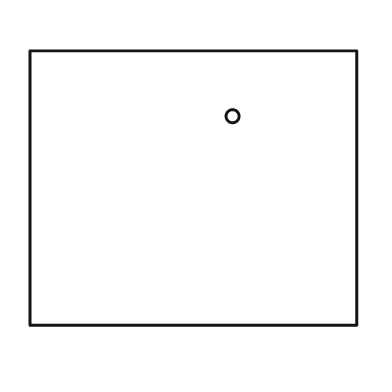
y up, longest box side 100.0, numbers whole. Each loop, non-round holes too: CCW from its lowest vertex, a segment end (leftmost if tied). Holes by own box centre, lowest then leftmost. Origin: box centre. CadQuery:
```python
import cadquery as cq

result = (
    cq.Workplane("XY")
    .moveTo(-50.0, -42.0)
    .lineTo(50.0, -42.0)
    .lineTo(50.0, 42.0)
    .lineTo(-50.0, 42.0)
    .close()
    .moveTo(12.0, 22.0)
    .circle(2.0)
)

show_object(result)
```